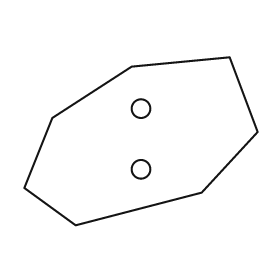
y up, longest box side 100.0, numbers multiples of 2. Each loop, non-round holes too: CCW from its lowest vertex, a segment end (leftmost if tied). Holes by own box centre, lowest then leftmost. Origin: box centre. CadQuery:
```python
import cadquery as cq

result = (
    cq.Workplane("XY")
    .moveTo(-28.0, -36.0)
    .lineTo(26.0, -22.0)
    .lineTo(50.0, 4.0)
    .lineTo(38.0, 36.0)
    .lineTo(-4.0, 32.0)
    .lineTo(-38.0, 10.0)
    .lineTo(-50.0, -20.0)
    .close()
    .moveTo(0.0, -12.0)
    .circle(4.0)
    .moveTo(0.0, 14.0)
    .circle(4.0)
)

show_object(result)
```